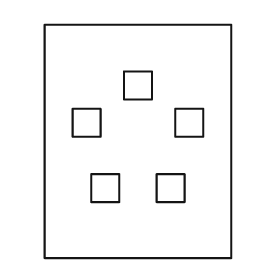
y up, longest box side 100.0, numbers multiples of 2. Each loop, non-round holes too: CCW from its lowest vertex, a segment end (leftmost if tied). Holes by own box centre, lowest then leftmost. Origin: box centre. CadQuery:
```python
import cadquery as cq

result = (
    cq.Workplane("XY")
    .moveTo(-40.0, -50.0)
    .lineTo(40.0, -50.0)
    .lineTo(40.0, 50.0)
    .lineTo(-40.0, 50.0)
    .close()
    .moveTo(-20.0, -26.0)
    .lineTo(-8.0, -26.0)
    .lineTo(-8.0, -14.0)
    .lineTo(-20.0, -14.0)
    .close()
    .moveTo(8.0, -26.0)
    .lineTo(20.0, -26.0)
    .lineTo(20.0, -14.0)
    .lineTo(8.0, -14.0)
    .close()
    .moveTo(-28.0, 2.0)
    .lineTo(-16.0, 2.0)
    .lineTo(-16.0, 14.0)
    .lineTo(-28.0, 14.0)
    .close()
    .moveTo(16.0, 2.0)
    .lineTo(28.0, 2.0)
    .lineTo(28.0, 14.0)
    .lineTo(16.0, 14.0)
    .close()
    .moveTo(-6.0, 18.0)
    .lineTo(6.0, 18.0)
    .lineTo(6.0, 30.0)
    .lineTo(-6.0, 30.0)
    .close()
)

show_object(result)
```